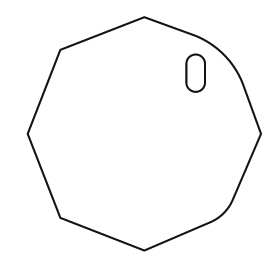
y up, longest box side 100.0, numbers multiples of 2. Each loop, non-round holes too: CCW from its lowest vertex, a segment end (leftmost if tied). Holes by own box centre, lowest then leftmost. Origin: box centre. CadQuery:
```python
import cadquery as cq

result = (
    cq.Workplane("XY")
    .moveTo(0.0, -50.0)
    .lineTo(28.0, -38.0)
    .threePointArc((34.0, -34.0), (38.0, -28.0))
    .lineTo(50.0, 0.0)
    .lineTo(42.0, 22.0)
    .threePointArc((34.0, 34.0), (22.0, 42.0))
    .lineTo(0.0, 50.0)
    .lineTo(-36.0, 36.0)
    .lineTo(-50.0, 0.0)
    .lineTo(-36.0, -36.0)
    .close()
    .moveTo(18.0, 22.0)
    .threePointArc((22.0, 18.0), (26.0, 22.0))
    .lineTo(26.0, 30.0)
    .threePointArc((22.0, 34.0), (18.0, 30.0))
    .close()
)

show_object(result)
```